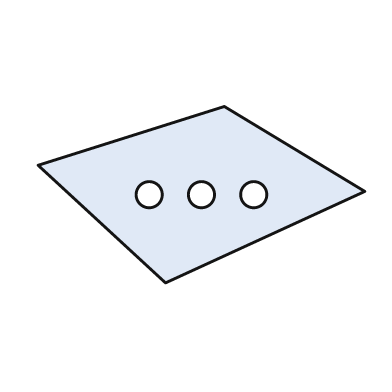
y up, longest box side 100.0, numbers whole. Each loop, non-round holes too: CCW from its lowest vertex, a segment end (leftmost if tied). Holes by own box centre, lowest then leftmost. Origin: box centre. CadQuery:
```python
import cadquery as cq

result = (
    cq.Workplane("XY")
    .moveTo(-11.0, -27.0)
    .lineTo(50.0, 1.0)
    .lineTo(7.0, 27.0)
    .lineTo(-50.0, 9.0)
    .close()
    .moveTo(-16.0, 0.0)
    .circle(4.0)
    .moveTo(0.0, 0.0)
    .circle(4.0)
    .moveTo(16.0, 0.0)
    .circle(4.0)
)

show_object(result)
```